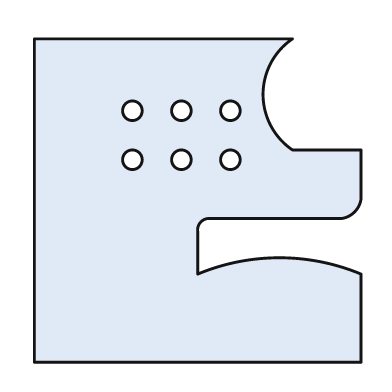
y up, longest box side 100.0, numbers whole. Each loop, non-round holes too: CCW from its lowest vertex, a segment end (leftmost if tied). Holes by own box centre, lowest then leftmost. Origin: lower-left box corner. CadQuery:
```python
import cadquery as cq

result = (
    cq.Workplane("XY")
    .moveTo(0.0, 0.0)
    .lineTo(100.0, 0.0)
    .lineTo(100.0, 27.0)
    .threePointArc((75.0, 32.0), (50.0, 27.0))
    .lineTo(50.0, 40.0)
    .threePointArc((51.0, 43.0), (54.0, 44.0))
    .lineTo(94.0, 44.0)
    .threePointArc((98.0, 46.0), (100.0, 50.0))
    .lineTo(100.0, 65.0)
    .lineTo(79.0, 65.0)
    .threePointArc((70.0, 82.0), (79.0, 99.0))
    .lineTo(0.0, 99.0)
    .close()
    .moveTo(30.0, 62.0)
    .circle(3.0)
    .moveTo(45.0, 62.0)
    .circle(3.0)
    .moveTo(60.0, 62.0)
    .circle(3.0)
    .moveTo(30.0, 77.0)
    .circle(3.0)
    .moveTo(45.0, 77.0)
    .circle(3.0)
    .moveTo(60.0, 77.0)
    .circle(3.0)
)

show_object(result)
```